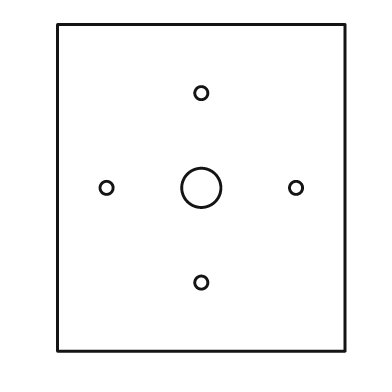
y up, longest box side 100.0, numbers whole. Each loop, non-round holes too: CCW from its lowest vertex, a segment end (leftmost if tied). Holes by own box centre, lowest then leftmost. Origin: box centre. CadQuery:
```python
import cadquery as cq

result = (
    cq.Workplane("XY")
    .moveTo(-44.0, -50.0)
    .lineTo(44.0, -50.0)
    .lineTo(44.0, 50.0)
    .lineTo(-44.0, 50.0)
    .close()
    .moveTo(0.0, -29.0)
    .circle(2.0)
    .moveTo(-29.0, 0.0)
    .circle(2.0)
    .moveTo(0.0, 0.0)
    .circle(6.0)
    .moveTo(29.0, 0.0)
    .circle(2.0)
    .moveTo(0.0, 29.0)
    .circle(2.0)
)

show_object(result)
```